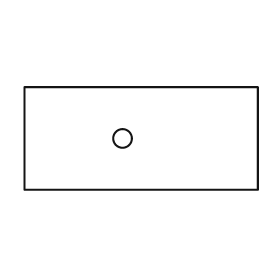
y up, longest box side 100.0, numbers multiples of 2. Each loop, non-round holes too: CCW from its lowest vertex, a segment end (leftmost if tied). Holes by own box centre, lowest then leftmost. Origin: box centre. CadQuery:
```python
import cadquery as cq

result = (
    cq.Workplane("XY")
    .moveTo(-50.0, -22.0)
    .lineTo(50.0, -22.0)
    .lineTo(50.0, 22.0)
    .lineTo(-50.0, 22.0)
    .close()
    .moveTo(-8.0, 0.0)
    .circle(4.0)
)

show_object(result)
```